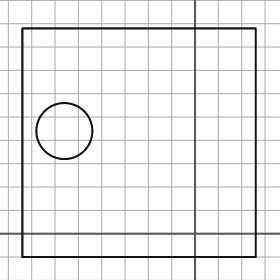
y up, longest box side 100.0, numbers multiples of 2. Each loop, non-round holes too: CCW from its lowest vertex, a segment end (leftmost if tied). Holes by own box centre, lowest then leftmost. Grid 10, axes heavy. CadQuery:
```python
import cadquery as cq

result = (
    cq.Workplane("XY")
    .moveTo(-74.0, -10.0)
    .lineTo(26.0, -10.0)
    .lineTo(26.0, 88.0)
    .lineTo(-74.0, 88.0)
    .close()
    .moveTo(-56.0, 44.0)
    .circle(12.0)
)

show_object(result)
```